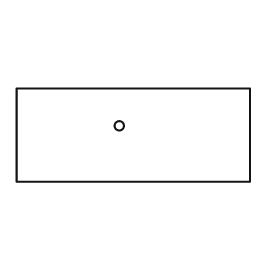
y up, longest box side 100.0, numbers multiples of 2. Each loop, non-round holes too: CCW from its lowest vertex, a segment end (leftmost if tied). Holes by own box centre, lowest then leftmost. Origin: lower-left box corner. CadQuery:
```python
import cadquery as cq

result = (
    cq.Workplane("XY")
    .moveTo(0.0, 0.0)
    .lineTo(100.0, 0.0)
    .lineTo(100.0, 40.0)
    .lineTo(0.0, 40.0)
    .close()
    .moveTo(44.0, 24.0)
    .circle(2.0)
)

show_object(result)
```